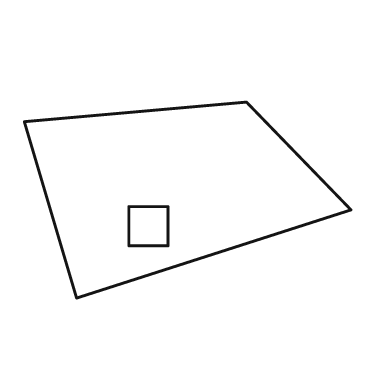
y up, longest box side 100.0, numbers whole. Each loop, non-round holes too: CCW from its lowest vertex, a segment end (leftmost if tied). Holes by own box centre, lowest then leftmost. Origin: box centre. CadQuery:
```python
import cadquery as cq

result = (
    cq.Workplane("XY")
    .moveTo(-34.0, -30.0)
    .lineTo(50.0, -3.0)
    .lineTo(18.0, 30.0)
    .lineTo(-50.0, 24.0)
    .close()
    .moveTo(-18.0, -14.0)
    .lineTo(-6.0, -14.0)
    .lineTo(-6.0, -2.0)
    .lineTo(-18.0, -2.0)
    .close()
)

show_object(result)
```